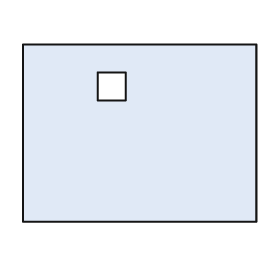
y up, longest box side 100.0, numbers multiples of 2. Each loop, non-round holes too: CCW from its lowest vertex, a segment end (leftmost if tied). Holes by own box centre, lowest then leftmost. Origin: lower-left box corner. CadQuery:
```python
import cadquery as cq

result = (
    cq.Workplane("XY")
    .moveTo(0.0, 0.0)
    .lineTo(100.0, 0.0)
    .lineTo(100.0, 76.0)
    .lineTo(0.0, 76.0)
    .close()
    .moveTo(32.0, 52.0)
    .lineTo(44.0, 52.0)
    .lineTo(44.0, 64.0)
    .lineTo(32.0, 64.0)
    .close()
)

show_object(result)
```